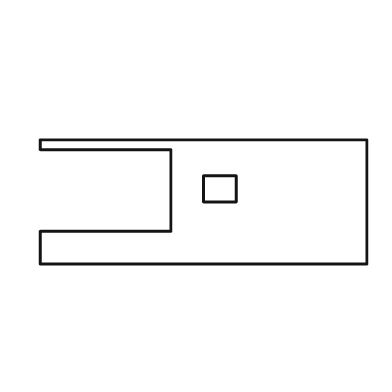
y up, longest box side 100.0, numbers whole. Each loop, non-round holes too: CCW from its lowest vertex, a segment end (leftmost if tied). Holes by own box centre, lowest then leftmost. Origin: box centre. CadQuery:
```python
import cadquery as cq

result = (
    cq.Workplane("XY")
    .moveTo(-50.0, -19.0)
    .lineTo(50.0, -19.0)
    .lineTo(50.0, 19.0)
    .lineTo(-50.0, 19.0)
    .lineTo(-50.0, 16.0)
    .lineTo(-10.0, 16.0)
    .lineTo(-10.0, -9.0)
    .lineTo(-50.0, -9.0)
    .close()
    .moveTo(0.0, 0.0)
    .lineTo(10.0, 0.0)
    .lineTo(10.0, 8.0)
    .lineTo(0.0, 8.0)
    .close()
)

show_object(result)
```